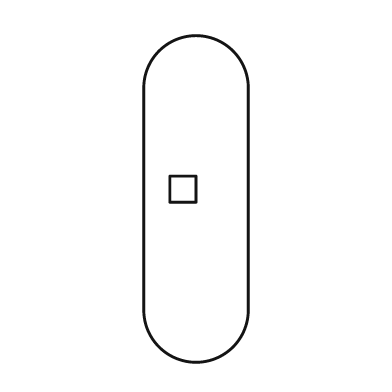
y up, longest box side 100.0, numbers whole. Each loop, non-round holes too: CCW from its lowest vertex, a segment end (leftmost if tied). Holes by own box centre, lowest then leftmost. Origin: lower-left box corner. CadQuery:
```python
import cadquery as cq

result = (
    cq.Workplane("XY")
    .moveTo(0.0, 16.0)
    .threePointArc((16.0, 0.0), (32.0, 16.0))
    .lineTo(32.0, 84.0)
    .threePointArc((16.0, 100.0), (0.0, 84.0))
    .close()
    .moveTo(8.0, 49.0)
    .lineTo(16.0, 49.0)
    .lineTo(16.0, 57.0)
    .lineTo(8.0, 57.0)
    .close()
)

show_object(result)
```